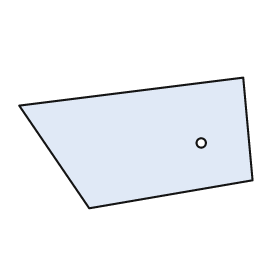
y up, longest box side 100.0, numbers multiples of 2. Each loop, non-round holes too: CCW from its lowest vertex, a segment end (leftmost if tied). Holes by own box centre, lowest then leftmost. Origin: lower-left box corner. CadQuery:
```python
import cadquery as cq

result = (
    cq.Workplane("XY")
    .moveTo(30.0, 0.0)
    .lineTo(100.0, 12.0)
    .lineTo(96.0, 56.0)
    .lineTo(0.0, 44.0)
    .close()
    .moveTo(78.0, 28.0)
    .circle(2.0)
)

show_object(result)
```